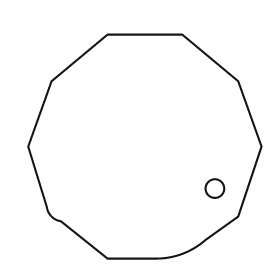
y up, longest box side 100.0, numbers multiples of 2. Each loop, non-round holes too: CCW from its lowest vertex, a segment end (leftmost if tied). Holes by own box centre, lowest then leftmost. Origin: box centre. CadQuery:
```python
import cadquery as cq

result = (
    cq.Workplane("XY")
    .moveTo(-16.0, -48.0)
    .lineTo(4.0, -48.0)
    .threePointArc((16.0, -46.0), (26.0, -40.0))
    .lineTo(40.0, -30.0)
    .lineTo(50.0, 0.0)
    .lineTo(40.0, 28.0)
    .lineTo(16.0, 48.0)
    .lineTo(-16.0, 48.0)
    .lineTo(-40.0, 28.0)
    .lineTo(-50.0, 0.0)
    .lineTo(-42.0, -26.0)
    .threePointArc((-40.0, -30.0), (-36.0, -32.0))
    .close()
    .moveTo(30.0, -18.0)
    .circle(4.0)
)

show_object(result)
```